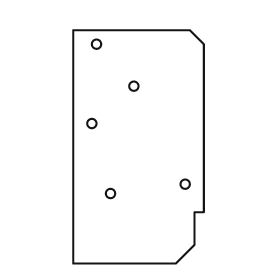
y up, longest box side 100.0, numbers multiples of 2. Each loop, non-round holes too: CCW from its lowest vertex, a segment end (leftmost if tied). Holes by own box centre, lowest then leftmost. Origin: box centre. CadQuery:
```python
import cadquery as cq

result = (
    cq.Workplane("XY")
    .moveTo(-28.0, -50.0)
    .lineTo(16.0, -50.0)
    .lineTo(24.0, -42.0)
    .lineTo(24.0, -28.0)
    .lineTo(28.0, -28.0)
    .lineTo(28.0, 44.0)
    .lineTo(22.0, 50.0)
    .lineTo(-28.0, 50.0)
    .close()
    .moveTo(-12.0, -20.0)
    .circle(2.0)
    .moveTo(20.0, -16.0)
    .circle(2.0)
    .moveTo(-20.0, 10.0)
    .circle(2.0)
    .moveTo(-2.0, 26.0)
    .circle(2.0)
    .moveTo(-18.0, 44.0)
    .circle(2.0)
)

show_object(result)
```